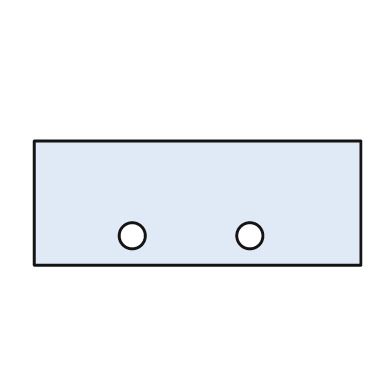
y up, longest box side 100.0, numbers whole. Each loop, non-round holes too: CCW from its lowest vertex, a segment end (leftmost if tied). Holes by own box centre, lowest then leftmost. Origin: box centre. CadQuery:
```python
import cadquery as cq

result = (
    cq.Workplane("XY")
    .moveTo(-50.0, -19.0)
    .lineTo(50.0, -19.0)
    .lineTo(50.0, 19.0)
    .lineTo(-50.0, 19.0)
    .close()
    .moveTo(-20.0, -10.0)
    .circle(4.0)
    .moveTo(16.0, -10.0)
    .circle(4.0)
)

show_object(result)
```